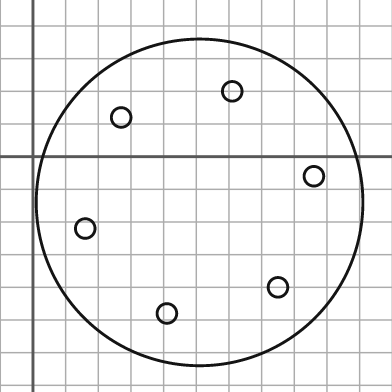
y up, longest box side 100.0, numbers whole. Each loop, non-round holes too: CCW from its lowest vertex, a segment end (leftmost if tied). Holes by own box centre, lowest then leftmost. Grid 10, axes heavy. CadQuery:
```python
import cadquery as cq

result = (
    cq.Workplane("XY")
    .moveTo(51.0, -14.0)
    .circle(50.0)
    .moveTo(41.0, -48.0)
    .circle(3.0)
    .moveTo(75.0, -40.0)
    .circle(3.0)
    .moveTo(16.0, -22.0)
    .circle(3.0)
    .moveTo(86.0, -6.0)
    .circle(3.0)
    .moveTo(27.0, 12.0)
    .circle(3.0)
    .moveTo(61.0, 20.0)
    .circle(3.0)
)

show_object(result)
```